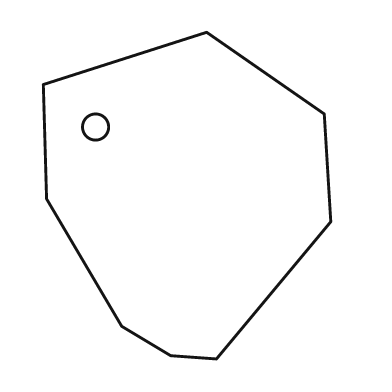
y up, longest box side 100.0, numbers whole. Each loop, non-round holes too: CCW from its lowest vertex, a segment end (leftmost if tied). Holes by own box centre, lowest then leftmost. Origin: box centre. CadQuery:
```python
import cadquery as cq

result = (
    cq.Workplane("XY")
    .moveTo(9.0, -50.0)
    .lineTo(44.0, -8.0)
    .lineTo(42.0, 25.0)
    .lineTo(6.0, 50.0)
    .lineTo(-44.0, 34.0)
    .lineTo(-43.0, -1.0)
    .lineTo(-20.0, -40.0)
    .lineTo(-5.0, -49.0)
    .close()
    .moveTo(-28.0, 21.0)
    .circle(4.0)
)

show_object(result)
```